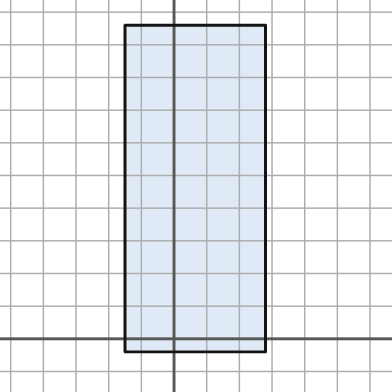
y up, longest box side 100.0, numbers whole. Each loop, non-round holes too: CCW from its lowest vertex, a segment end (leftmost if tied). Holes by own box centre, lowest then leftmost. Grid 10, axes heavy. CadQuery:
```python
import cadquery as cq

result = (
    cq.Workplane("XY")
    .moveTo(-15.0, -4.0)
    .lineTo(28.0, -4.0)
    .lineTo(28.0, 96.0)
    .lineTo(-15.0, 96.0)
    .close()
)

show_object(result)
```